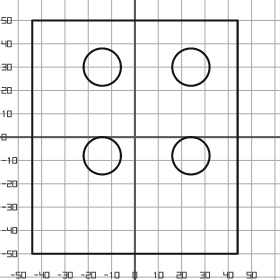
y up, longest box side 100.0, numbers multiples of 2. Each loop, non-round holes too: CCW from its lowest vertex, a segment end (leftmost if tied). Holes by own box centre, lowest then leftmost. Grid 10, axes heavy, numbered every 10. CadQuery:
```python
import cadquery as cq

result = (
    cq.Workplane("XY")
    .moveTo(-44.0, -50.0)
    .lineTo(44.0, -50.0)
    .lineTo(44.0, 50.0)
    .lineTo(-44.0, 50.0)
    .close()
    .moveTo(-14.0, -8.0)
    .circle(8.0)
    .moveTo(24.0, -8.0)
    .circle(8.0)
    .moveTo(-14.0, 30.0)
    .circle(8.0)
    .moveTo(24.0, 30.0)
    .circle(8.0)
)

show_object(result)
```